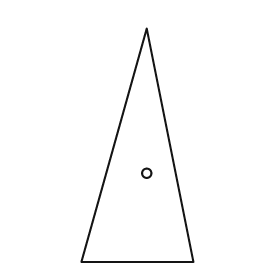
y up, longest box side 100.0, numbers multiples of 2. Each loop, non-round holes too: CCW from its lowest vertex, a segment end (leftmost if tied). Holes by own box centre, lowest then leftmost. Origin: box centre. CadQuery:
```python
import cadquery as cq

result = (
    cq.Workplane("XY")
    .moveTo(-24.0, -50.0)
    .lineTo(24.0, -50.0)
    .lineTo(4.0, 50.0)
    .close()
    .moveTo(4.0, -12.0)
    .circle(2.0)
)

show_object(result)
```